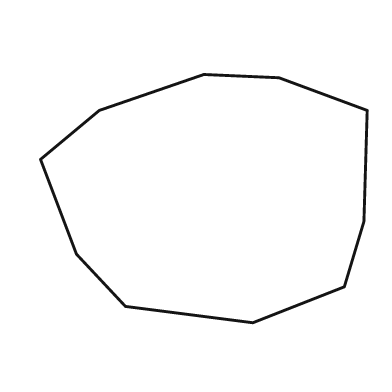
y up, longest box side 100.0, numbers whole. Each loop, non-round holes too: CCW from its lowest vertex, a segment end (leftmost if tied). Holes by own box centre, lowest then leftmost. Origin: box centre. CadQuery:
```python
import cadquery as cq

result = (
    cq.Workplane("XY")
    .moveTo(15.0, -38.0)
    .lineTo(43.0, -27.0)
    .lineTo(49.0, -7.0)
    .lineTo(50.0, 27.0)
    .lineTo(23.0, 37.0)
    .lineTo(0.0, 38.0)
    .lineTo(-32.0, 27.0)
    .lineTo(-50.0, 12.0)
    .lineTo(-39.0, -17.0)
    .lineTo(-24.0, -33.0)
    .close()
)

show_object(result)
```